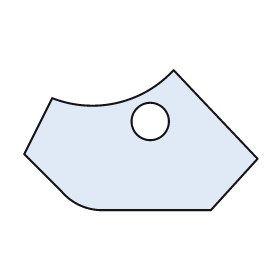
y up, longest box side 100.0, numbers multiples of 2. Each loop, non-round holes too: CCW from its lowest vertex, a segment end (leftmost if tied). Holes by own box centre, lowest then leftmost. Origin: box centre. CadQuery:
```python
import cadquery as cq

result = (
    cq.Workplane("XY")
    .moveTo(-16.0, -30.0)
    .lineTo(30.0, -30.0)
    .lineTo(50.0, -8.0)
    .lineTo(14.0, 30.0)
    .threePointArc((-10.0, 16.0), (-38.0, 18.0))
    .lineTo(-50.0, -6.0)
    .lineTo(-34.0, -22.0)
    .threePointArc((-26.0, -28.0), (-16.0, -30.0))
    .close()
    .moveTo(4.0, 8.0)
    .circle(8.0)
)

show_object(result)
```